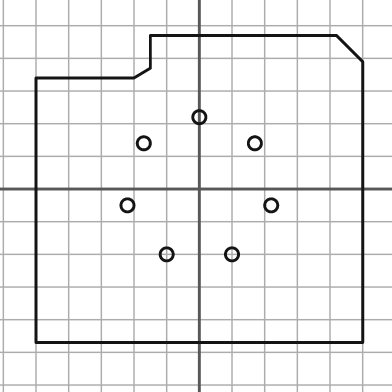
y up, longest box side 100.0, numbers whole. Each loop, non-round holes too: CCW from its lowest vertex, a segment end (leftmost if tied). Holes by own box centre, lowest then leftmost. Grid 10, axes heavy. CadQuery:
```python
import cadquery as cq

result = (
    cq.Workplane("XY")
    .moveTo(-50.0, -47.0)
    .lineTo(50.0, -47.0)
    .lineTo(50.0, 39.0)
    .lineTo(42.0, 47.0)
    .lineTo(-15.0, 47.0)
    .lineTo(-15.0, 37.0)
    .lineTo(-20.0, 34.0)
    .lineTo(-50.0, 34.0)
    .close()
    .moveTo(-10.0, -20.0)
    .circle(2.0)
    .moveTo(10.0, -20.0)
    .circle(2.0)
    .moveTo(-22.0, -5.0)
    .circle(2.0)
    .moveTo(22.0, -5.0)
    .circle(2.0)
    .moveTo(-17.0, 14.0)
    .circle(2.0)
    .moveTo(17.0, 14.0)
    .circle(2.0)
    .moveTo(0.0, 22.0)
    .circle(2.0)
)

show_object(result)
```